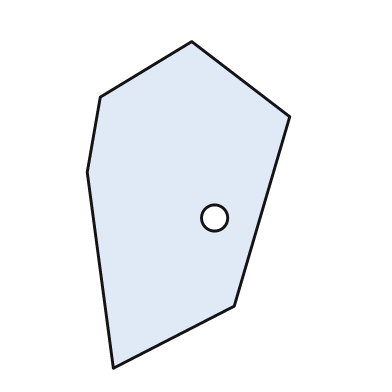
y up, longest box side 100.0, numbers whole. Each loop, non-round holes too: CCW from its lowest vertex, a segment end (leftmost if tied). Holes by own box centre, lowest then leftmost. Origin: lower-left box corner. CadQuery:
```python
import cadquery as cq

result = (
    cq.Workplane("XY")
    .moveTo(8.0, 0.0)
    .lineTo(45.0, 19.0)
    .lineTo(62.0, 77.0)
    .lineTo(32.0, 100.0)
    .lineTo(4.0, 83.0)
    .lineTo(0.0, 60.0)
    .close()
    .moveTo(39.0, 46.0)
    .circle(4.0)
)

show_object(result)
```